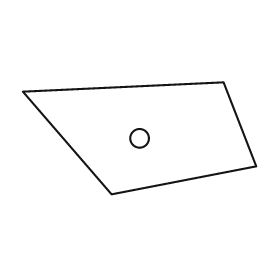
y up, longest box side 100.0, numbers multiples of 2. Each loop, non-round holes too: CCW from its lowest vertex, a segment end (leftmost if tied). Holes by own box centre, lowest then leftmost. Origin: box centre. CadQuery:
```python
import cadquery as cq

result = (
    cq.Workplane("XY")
    .moveTo(-12.0, -24.0)
    .lineTo(50.0, -12.0)
    .lineTo(36.0, 24.0)
    .lineTo(-50.0, 20.0)
    .close()
    .moveTo(0.0, 0.0)
    .circle(4.0)
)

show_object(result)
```